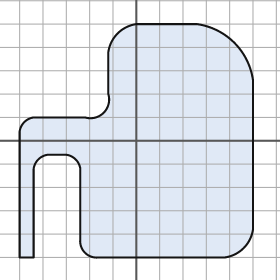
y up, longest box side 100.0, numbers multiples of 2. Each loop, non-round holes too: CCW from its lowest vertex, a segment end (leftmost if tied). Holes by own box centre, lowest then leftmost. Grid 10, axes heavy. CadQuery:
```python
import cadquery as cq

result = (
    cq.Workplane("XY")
    .moveTo(-50.0, -50.0)
    .lineTo(-44.0, -50.0)
    .lineTo(-44.0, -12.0)
    .threePointArc((-42.0, -8.0), (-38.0, -6.0))
    .lineTo(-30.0, -6.0)
    .threePointArc((-26.0, -8.0), (-24.0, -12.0))
    .lineTo(-24.0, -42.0)
    .threePointArc((-22.0, -48.0), (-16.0, -50.0))
    .lineTo(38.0, -50.0)
    .threePointArc((46.0, -46.0), (50.0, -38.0))
    .lineTo(50.0, 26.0)
    .threePointArc((42.0, 42.0), (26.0, 50.0))
    .lineTo(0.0, 50.0)
    .threePointArc((-8.0, 46.0), (-12.0, 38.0))
    .lineTo(-12.0, 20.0)
    .threePointArc((-14.0, 12.0), (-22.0, 10.0))
    .lineTo(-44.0, 10.0)
    .threePointArc((-48.0, 8.0), (-50.0, 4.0))
    .close()
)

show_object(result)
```